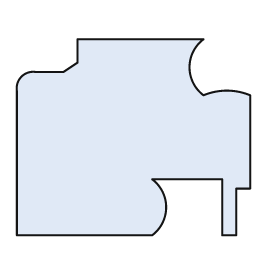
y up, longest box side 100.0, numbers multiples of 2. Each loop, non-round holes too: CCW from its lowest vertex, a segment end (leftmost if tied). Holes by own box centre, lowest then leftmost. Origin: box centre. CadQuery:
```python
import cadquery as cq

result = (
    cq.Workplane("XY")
    .moveTo(-50.0, -42.0)
    .lineTo(8.0, -42.0)
    .threePointArc((14.0, -30.0), (8.0, -18.0))
    .lineTo(38.0, -18.0)
    .lineTo(38.0, -42.0)
    .lineTo(44.0, -42.0)
    .lineTo(44.0, -22.0)
    .lineTo(50.0, -22.0)
    .lineTo(50.0, 18.0)
    .threePointArc((40.0, 20.0), (30.0, 18.0))
    .threePointArc((24.0, 30.0), (30.0, 42.0))
    .lineTo(-24.0, 42.0)
    .lineTo(-24.0, 32.0)
    .lineTo(-30.0, 28.0)
    .lineTo(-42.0, 28.0)
    .threePointArc((-48.0, 26.0), (-50.0, 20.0))
    .close()
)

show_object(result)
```